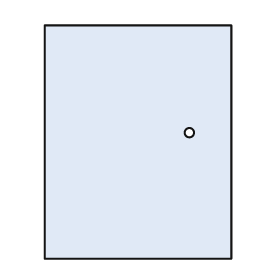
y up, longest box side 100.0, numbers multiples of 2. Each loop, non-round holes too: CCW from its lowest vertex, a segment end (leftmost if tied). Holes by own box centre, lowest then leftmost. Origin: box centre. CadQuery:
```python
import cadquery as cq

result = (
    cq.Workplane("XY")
    .moveTo(-40.0, -50.0)
    .lineTo(40.0, -50.0)
    .lineTo(40.0, 50.0)
    .lineTo(-40.0, 50.0)
    .close()
    .moveTo(22.0, 4.0)
    .circle(2.0)
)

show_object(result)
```